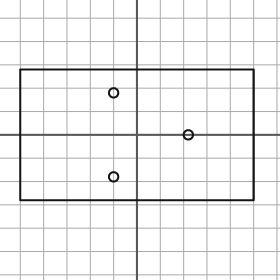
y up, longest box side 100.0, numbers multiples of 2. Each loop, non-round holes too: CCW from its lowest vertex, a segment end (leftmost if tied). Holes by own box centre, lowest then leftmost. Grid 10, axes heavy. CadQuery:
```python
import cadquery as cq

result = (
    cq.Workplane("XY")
    .moveTo(-50.0, -28.0)
    .lineTo(50.0, -28.0)
    .lineTo(50.0, 28.0)
    .lineTo(-50.0, 28.0)
    .close()
    .moveTo(-10.0, -18.0)
    .circle(2.0)
    .moveTo(22.0, 0.0)
    .circle(2.0)
    .moveTo(-10.0, 18.0)
    .circle(2.0)
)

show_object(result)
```